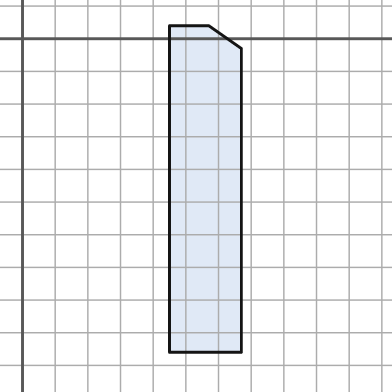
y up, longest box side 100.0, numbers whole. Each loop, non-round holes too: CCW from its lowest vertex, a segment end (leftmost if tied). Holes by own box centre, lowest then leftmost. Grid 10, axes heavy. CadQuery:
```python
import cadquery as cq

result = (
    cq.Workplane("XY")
    .moveTo(45.0, -96.0)
    .lineTo(67.0, -96.0)
    .lineTo(67.0, -3.0)
    .lineTo(57.0, 4.0)
    .lineTo(45.0, 4.0)
    .close()
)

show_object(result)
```